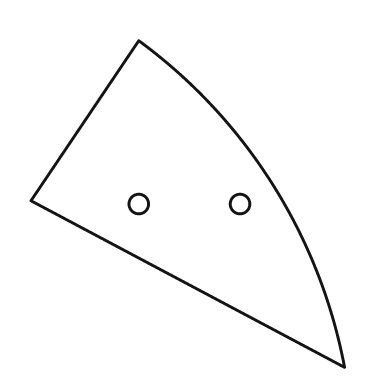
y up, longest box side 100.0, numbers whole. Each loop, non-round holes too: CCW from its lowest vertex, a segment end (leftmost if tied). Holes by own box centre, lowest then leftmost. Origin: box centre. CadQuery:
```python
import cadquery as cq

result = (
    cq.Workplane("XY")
    .moveTo(48.0, -50.0)
    .threePointArc((26.0, 6.0), (-15.0, 50.0))
    .lineTo(-48.0, 1.0)
    .close()
    .moveTo(-15.0, 0.0)
    .circle(3.0)
    .moveTo(16.0, 0.0)
    .circle(3.0)
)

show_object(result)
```